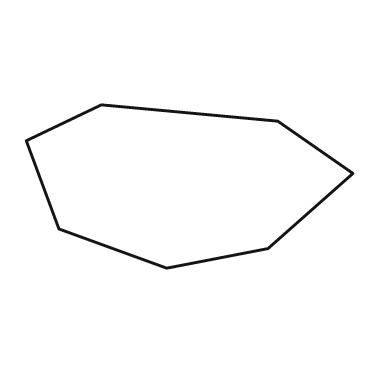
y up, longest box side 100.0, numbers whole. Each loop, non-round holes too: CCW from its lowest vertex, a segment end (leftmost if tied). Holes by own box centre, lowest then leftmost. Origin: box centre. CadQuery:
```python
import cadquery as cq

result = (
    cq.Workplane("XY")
    .moveTo(-7.0, -25.0)
    .lineTo(24.0, -19.0)
    .lineTo(50.0, 4.0)
    .lineTo(27.0, 20.0)
    .lineTo(-27.0, 25.0)
    .lineTo(-50.0, 14.0)
    .lineTo(-40.0, -13.0)
    .close()
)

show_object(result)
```